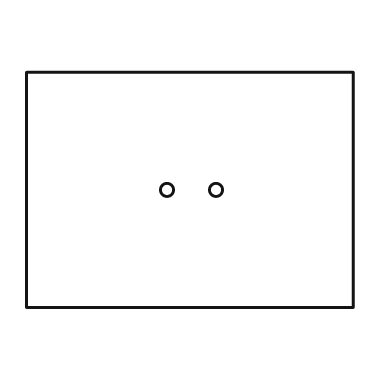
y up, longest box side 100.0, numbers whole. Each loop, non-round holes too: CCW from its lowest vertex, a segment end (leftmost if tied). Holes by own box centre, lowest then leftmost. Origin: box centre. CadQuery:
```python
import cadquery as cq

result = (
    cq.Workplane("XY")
    .moveTo(-50.0, -36.0)
    .lineTo(50.0, -36.0)
    .lineTo(50.0, 36.0)
    .lineTo(-50.0, 36.0)
    .close()
    .moveTo(-7.0, 0.0)
    .circle(2.0)
    .moveTo(8.0, 0.0)
    .circle(2.0)
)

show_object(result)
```